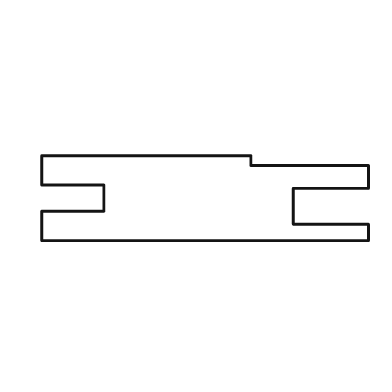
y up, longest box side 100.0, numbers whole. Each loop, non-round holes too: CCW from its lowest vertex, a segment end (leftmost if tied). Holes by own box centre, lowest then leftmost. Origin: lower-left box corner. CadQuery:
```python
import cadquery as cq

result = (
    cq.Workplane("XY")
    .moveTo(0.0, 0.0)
    .lineTo(100.0, 0.0)
    .lineTo(100.0, 5.0)
    .lineTo(77.0, 5.0)
    .lineTo(77.0, 16.0)
    .lineTo(100.0, 16.0)
    .lineTo(100.0, 23.0)
    .lineTo(64.0, 23.0)
    .lineTo(64.0, 26.0)
    .lineTo(0.0, 26.0)
    .lineTo(0.0, 17.0)
    .lineTo(19.0, 17.0)
    .lineTo(19.0, 9.0)
    .lineTo(0.0, 9.0)
    .close()
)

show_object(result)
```